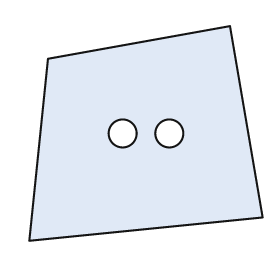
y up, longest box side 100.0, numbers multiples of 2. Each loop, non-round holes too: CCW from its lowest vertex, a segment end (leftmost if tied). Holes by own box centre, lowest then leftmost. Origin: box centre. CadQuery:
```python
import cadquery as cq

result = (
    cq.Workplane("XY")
    .moveTo(-50.0, -46.0)
    .lineTo(50.0, -36.0)
    .lineTo(36.0, 46.0)
    .lineTo(-42.0, 32.0)
    .close()
    .moveTo(-10.0, 0.0)
    .circle(6.0)
    .moveTo(10.0, 0.0)
    .circle(6.0)
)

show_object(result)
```